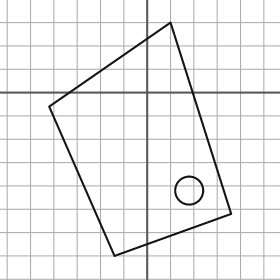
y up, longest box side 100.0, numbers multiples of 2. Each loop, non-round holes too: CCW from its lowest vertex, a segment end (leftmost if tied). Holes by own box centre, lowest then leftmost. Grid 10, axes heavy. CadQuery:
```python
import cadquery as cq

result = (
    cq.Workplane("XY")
    .moveTo(-14.0, -70.0)
    .lineTo(36.0, -52.0)
    .lineTo(10.0, 30.0)
    .lineTo(-42.0, -6.0)
    .close()
    .moveTo(18.0, -42.0)
    .circle(6.0)
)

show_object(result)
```